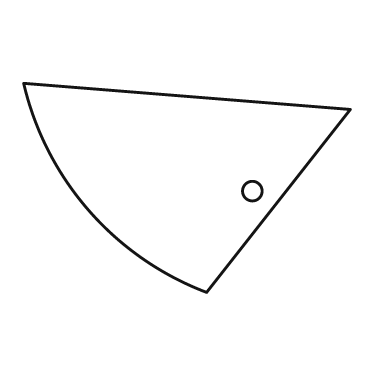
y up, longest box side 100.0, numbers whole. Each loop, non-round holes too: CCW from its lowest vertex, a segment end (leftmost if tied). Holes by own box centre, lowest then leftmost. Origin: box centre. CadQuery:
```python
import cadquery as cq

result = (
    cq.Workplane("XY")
    .moveTo(6.0, -32.0)
    .lineTo(50.0, 24.0)
    .lineTo(-50.0, 32.0)
    .threePointArc((-30.0, -7.0), (6.0, -32.0))
    .close()
    .moveTo(20.0, -1.0)
    .circle(3.0)
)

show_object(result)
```